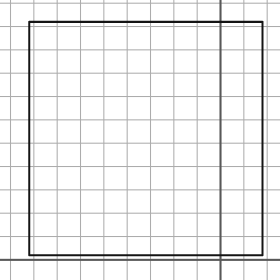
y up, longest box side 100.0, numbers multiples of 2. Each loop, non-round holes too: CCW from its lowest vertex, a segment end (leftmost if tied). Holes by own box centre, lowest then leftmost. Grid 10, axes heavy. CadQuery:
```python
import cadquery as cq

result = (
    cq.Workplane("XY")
    .moveTo(-82.0, 2.0)
    .lineTo(18.0, 2.0)
    .lineTo(18.0, 102.0)
    .lineTo(-82.0, 102.0)
    .close()
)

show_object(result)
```